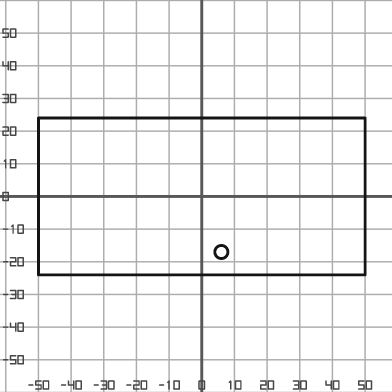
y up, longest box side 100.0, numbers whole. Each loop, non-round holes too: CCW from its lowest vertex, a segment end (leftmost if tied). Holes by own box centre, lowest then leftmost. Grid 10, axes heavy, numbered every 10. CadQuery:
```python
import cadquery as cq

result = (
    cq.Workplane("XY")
    .moveTo(-50.0, -24.0)
    .lineTo(50.0, -24.0)
    .lineTo(50.0, 24.0)
    .lineTo(-50.0, 24.0)
    .close()
    .moveTo(6.0, -17.0)
    .circle(2.0)
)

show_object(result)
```